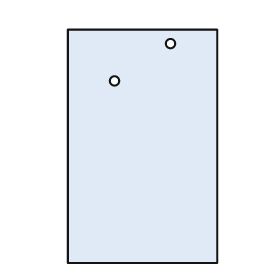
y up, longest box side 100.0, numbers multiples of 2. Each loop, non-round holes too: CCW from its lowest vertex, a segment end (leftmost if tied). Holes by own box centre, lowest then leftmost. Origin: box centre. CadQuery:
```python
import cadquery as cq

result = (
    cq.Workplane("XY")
    .moveTo(-32.0, -50.0)
    .lineTo(32.0, -50.0)
    .lineTo(32.0, 50.0)
    .lineTo(-32.0, 50.0)
    .close()
    .moveTo(-12.0, 28.0)
    .circle(2.0)
    .moveTo(12.0, 44.0)
    .circle(2.0)
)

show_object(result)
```